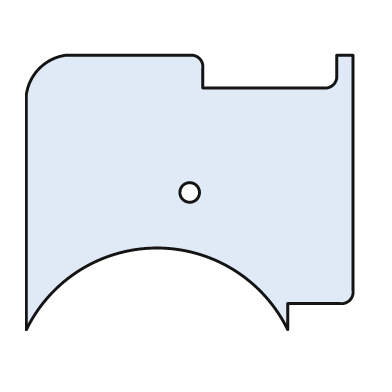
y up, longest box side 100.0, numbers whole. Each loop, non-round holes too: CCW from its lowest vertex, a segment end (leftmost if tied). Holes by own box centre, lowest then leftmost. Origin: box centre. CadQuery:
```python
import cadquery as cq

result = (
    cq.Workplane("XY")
    .moveTo(-50.0, -42.0)
    .threePointArc((-10.0, -17.0), (30.0, -42.0))
    .lineTo(30.0, -34.0)
    .lineTo(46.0, -34.0)
    .threePointArc((49.0, -33.0), (50.0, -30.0))
    .lineTo(50.0, 42.0)
    .lineTo(45.0, 42.0)
    .lineTo(45.0, 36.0)
    .threePointArc((44.0, 33.0), (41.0, 32.0))
    .lineTo(4.0, 32.0)
    .lineTo(4.0, 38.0)
    .threePointArc((3.0, 41.0), (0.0, 42.0))
    .lineTo(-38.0, 42.0)
    .threePointArc((-46.0, 38.0), (-50.0, 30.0))
    .close()
    .moveTo(0.0, 0.0)
    .circle(3.0)
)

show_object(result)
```